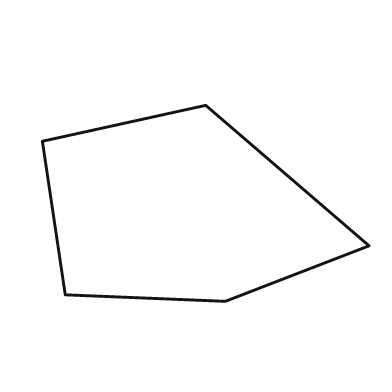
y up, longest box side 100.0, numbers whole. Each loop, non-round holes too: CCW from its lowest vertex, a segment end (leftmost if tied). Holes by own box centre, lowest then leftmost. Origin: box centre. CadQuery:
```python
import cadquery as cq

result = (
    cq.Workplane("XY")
    .moveTo(6.0, -30.0)
    .lineTo(50.0, -13.0)
    .lineTo(0.0, 30.0)
    .lineTo(-50.0, 19.0)
    .lineTo(-43.0, -28.0)
    .close()
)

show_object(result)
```